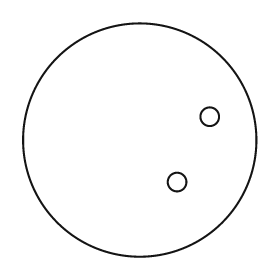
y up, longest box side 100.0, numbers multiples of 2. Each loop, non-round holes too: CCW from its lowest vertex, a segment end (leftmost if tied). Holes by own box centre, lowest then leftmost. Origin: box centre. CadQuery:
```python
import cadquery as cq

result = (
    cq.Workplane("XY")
    .moveTo(0.0, 0.0)
    .circle(50.0)
    .moveTo(16.0, -18.0)
    .circle(4.0)
    .moveTo(30.0, 10.0)
    .circle(4.0)
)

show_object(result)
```